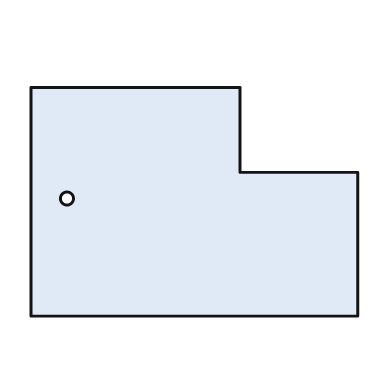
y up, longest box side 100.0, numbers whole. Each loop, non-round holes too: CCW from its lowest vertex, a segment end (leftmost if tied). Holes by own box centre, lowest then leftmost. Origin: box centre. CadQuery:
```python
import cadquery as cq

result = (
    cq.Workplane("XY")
    .moveTo(-50.0, -35.0)
    .lineTo(50.0, -35.0)
    .lineTo(50.0, 9.0)
    .lineTo(14.0, 9.0)
    .lineTo(14.0, 35.0)
    .lineTo(-50.0, 35.0)
    .close()
    .moveTo(-39.0, 1.0)
    .circle(2.0)
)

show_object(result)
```